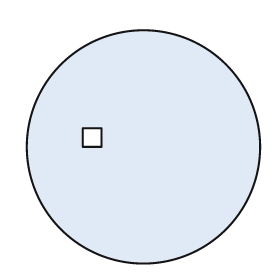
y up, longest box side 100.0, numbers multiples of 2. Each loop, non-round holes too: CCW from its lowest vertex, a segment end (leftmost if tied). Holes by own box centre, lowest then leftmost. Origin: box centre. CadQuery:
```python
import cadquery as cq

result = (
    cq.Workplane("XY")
    .moveTo(0.0, 0.0)
    .circle(50.0)
    .moveTo(-26.0, 0.0)
    .lineTo(-18.0, 0.0)
    .lineTo(-18.0, 8.0)
    .lineTo(-26.0, 8.0)
    .close()
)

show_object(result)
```